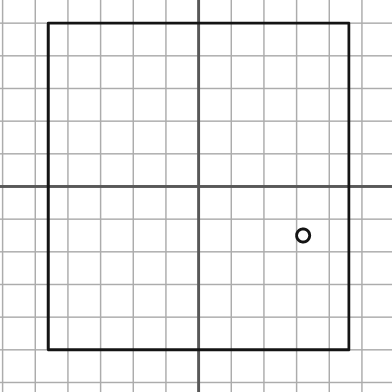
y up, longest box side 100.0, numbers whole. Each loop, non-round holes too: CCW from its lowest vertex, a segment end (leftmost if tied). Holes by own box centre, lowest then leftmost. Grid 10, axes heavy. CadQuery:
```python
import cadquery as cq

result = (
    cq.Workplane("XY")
    .moveTo(-46.0, -50.0)
    .lineTo(46.0, -50.0)
    .lineTo(46.0, 50.0)
    .lineTo(-46.0, 50.0)
    .close()
    .moveTo(32.0, -15.0)
    .circle(2.0)
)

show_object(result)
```